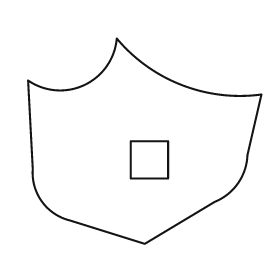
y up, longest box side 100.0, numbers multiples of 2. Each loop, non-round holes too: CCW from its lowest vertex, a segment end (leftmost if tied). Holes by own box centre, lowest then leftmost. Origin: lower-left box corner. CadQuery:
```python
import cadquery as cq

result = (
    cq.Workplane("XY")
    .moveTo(50.0, 0.0)
    .lineTo(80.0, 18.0)
    .threePointArc((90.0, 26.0), (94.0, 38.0))
    .lineTo(100.0, 64.0)
    .threePointArc((66.0, 68.0), (38.0, 88.0))
    .threePointArc((24.0, 68.0), (0.0, 70.0))
    .lineTo(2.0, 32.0)
    .threePointArc((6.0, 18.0), (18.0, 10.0))
    .close()
    .moveTo(44.0, 28.0)
    .lineTo(60.0, 28.0)
    .lineTo(60.0, 44.0)
    .lineTo(44.0, 44.0)
    .close()
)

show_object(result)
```